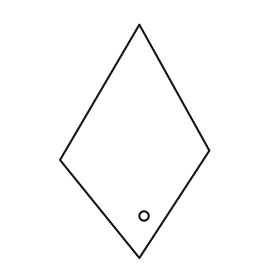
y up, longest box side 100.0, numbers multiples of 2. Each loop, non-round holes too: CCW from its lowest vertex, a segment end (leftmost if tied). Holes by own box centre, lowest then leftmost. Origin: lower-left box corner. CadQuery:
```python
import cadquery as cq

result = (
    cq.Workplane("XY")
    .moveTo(34.0, 0.0)
    .lineTo(64.0, 46.0)
    .lineTo(34.0, 100.0)
    .lineTo(0.0, 42.0)
    .close()
    .moveTo(36.0, 18.0)
    .circle(2.0)
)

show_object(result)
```